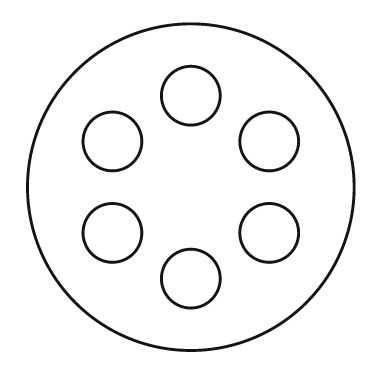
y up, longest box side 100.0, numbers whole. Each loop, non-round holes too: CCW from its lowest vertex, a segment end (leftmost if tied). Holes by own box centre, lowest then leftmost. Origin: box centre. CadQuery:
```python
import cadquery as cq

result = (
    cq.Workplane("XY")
    .moveTo(0.0, 0.0)
    .circle(50.0)
    .moveTo(0.0, -28.0)
    .circle(9.0)
    .moveTo(-24.0, -14.0)
    .circle(9.0)
    .moveTo(24.0, -14.0)
    .circle(9.0)
    .moveTo(-24.0, 14.0)
    .circle(9.0)
    .moveTo(24.0, 14.0)
    .circle(9.0)
    .moveTo(0.0, 28.0)
    .circle(9.0)
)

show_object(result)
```